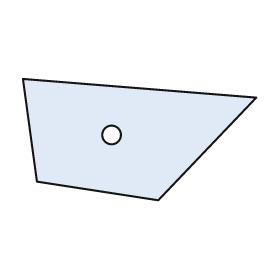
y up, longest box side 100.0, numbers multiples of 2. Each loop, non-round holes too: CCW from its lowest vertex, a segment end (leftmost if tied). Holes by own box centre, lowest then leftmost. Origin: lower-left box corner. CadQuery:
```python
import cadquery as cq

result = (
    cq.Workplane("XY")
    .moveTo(58.0, 0.0)
    .lineTo(100.0, 44.0)
    .lineTo(0.0, 52.0)
    .lineTo(6.0, 8.0)
    .close()
    .moveTo(38.0, 28.0)
    .circle(4.0)
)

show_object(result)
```